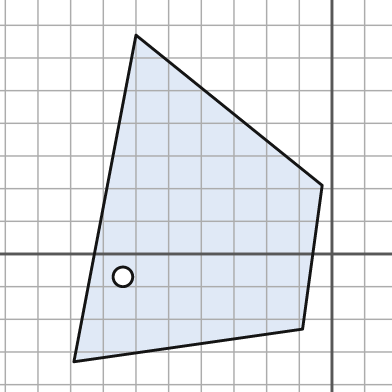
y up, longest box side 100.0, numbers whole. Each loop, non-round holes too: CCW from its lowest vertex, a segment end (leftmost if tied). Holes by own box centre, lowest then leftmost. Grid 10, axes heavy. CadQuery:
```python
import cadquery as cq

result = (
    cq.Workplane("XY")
    .moveTo(-79.0, -33.0)
    .lineTo(-9.0, -23.0)
    .lineTo(-3.0, 21.0)
    .lineTo(-60.0, 67.0)
    .close()
    .moveTo(-64.0, -7.0)
    .circle(3.0)
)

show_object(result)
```